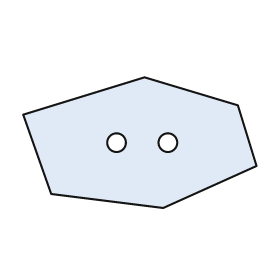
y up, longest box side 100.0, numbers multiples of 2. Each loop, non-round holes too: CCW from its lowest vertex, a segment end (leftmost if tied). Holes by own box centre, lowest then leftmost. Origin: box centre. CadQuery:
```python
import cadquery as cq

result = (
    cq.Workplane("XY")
    .moveTo(10.0, -28.0)
    .lineTo(50.0, -10.0)
    .lineTo(42.0, 16.0)
    .lineTo(2.0, 28.0)
    .lineTo(-50.0, 12.0)
    .lineTo(-38.0, -22.0)
    .close()
    .moveTo(-10.0, 0.0)
    .circle(4.0)
    .moveTo(12.0, 0.0)
    .circle(4.0)
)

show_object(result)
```